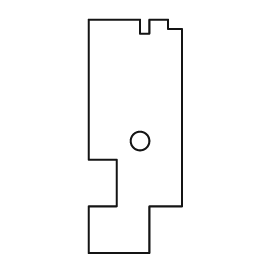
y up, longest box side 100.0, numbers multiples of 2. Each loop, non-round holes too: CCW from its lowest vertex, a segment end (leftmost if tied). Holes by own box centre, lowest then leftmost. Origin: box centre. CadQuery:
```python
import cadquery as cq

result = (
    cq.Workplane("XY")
    .moveTo(-20.0, -50.0)
    .lineTo(6.0, -50.0)
    .lineTo(6.0, -30.0)
    .lineTo(20.0, -30.0)
    .lineTo(20.0, 46.0)
    .lineTo(14.0, 46.0)
    .lineTo(14.0, 50.0)
    .lineTo(6.0, 50.0)
    .lineTo(6.0, 44.0)
    .lineTo(2.0, 44.0)
    .lineTo(2.0, 50.0)
    .lineTo(-20.0, 50.0)
    .lineTo(-20.0, -10.0)
    .lineTo(-8.0, -10.0)
    .lineTo(-8.0, -30.0)
    .lineTo(-20.0, -30.0)
    .close()
    .moveTo(2.0, -2.0)
    .circle(4.0)
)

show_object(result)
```